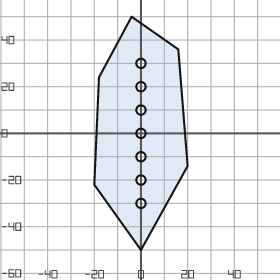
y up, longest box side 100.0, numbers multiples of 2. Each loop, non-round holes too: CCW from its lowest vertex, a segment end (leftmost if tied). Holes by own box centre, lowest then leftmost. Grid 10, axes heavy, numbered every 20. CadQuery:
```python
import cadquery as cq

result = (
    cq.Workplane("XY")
    .moveTo(0.0, -50.0)
    .lineTo(20.0, -14.0)
    .lineTo(16.0, 36.0)
    .lineTo(-4.0, 50.0)
    .lineTo(-18.0, 24.0)
    .lineTo(-20.0, -22.0)
    .close()
    .moveTo(0.0, -30.0)
    .circle(2.0)
    .moveTo(0.0, -20.0)
    .circle(2.0)
    .moveTo(0.0, -10.0)
    .circle(2.0)
    .moveTo(0.0, 0.0)
    .circle(2.0)
    .moveTo(0.0, 10.0)
    .circle(2.0)
    .moveTo(0.0, 20.0)
    .circle(2.0)
    .moveTo(0.0, 30.0)
    .circle(2.0)
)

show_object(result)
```